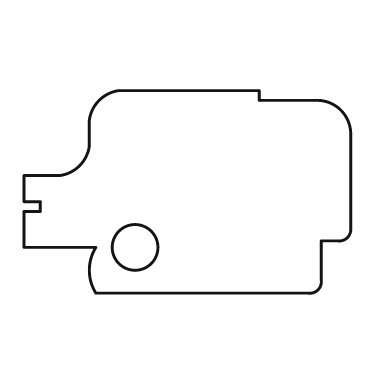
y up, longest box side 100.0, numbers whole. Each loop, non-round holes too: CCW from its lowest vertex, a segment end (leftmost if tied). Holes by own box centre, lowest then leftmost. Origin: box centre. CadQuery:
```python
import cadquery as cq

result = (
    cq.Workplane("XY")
    .moveTo(-28.0, -31.0)
    .lineTo(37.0, -31.0)
    .threePointArc((40.0, -30.0), (41.0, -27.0))
    .lineTo(41.0, -15.0)
    .lineTo(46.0, -15.0)
    .threePointArc((49.0, -14.0), (50.0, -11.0))
    .lineTo(50.0, 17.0)
    .threePointArc((47.0, 25.0), (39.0, 28.0))
    .lineTo(22.0, 28.0)
    .lineTo(22.0, 31.0)
    .lineTo(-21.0, 31.0)
    .threePointArc((-27.0, 28.0), (-30.0, 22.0))
    .lineTo(-30.0, 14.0)
    .threePointArc((-33.0, 8.0), (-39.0, 5.0))
    .lineTo(-50.0, 5.0)
    .lineTo(-50.0, -3.0)
    .lineTo(-45.0, -3.0)
    .lineTo(-45.0, -6.0)
    .lineTo(-50.0, -6.0)
    .lineTo(-50.0, -17.0)
    .lineTo(-28.0, -17.0)
    .threePointArc((-30.0, -24.0), (-28.0, -31.0))
    .close()
    .moveTo(-16.0, -17.0)
    .circle(7.0)
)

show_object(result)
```